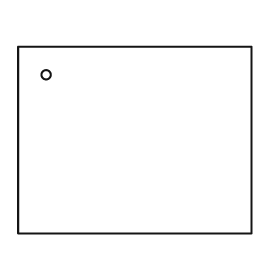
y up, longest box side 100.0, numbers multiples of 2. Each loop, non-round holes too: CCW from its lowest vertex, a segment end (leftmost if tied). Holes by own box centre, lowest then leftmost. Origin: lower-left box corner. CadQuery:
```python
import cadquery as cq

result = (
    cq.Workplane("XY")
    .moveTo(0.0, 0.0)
    .lineTo(100.0, 0.0)
    .lineTo(100.0, 80.0)
    .lineTo(0.0, 80.0)
    .close()
    .moveTo(12.0, 68.0)
    .circle(2.0)
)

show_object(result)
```